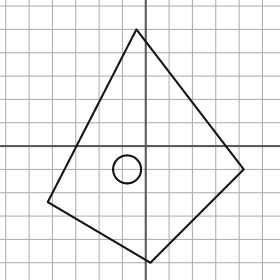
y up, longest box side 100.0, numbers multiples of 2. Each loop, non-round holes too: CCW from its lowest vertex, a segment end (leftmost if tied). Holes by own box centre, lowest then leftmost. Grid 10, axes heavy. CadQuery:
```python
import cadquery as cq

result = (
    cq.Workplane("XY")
    .moveTo(2.0, -50.0)
    .lineTo(42.0, -10.0)
    .lineTo(-4.0, 50.0)
    .lineTo(-42.0, -24.0)
    .close()
    .moveTo(-8.0, -10.0)
    .circle(6.0)
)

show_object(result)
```